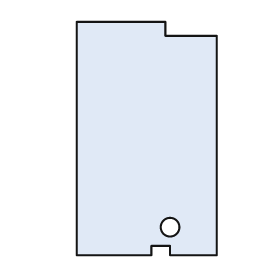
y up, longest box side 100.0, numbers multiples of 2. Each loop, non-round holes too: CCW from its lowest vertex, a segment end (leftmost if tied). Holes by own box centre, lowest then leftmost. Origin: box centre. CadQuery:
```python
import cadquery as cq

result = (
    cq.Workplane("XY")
    .moveTo(-30.0, -50.0)
    .lineTo(2.0, -50.0)
    .lineTo(2.0, -46.0)
    .lineTo(10.0, -46.0)
    .lineTo(10.0, -50.0)
    .lineTo(30.0, -50.0)
    .lineTo(30.0, 44.0)
    .lineTo(8.0, 44.0)
    .lineTo(8.0, 50.0)
    .lineTo(-30.0, 50.0)
    .close()
    .moveTo(10.0, -38.0)
    .circle(4.0)
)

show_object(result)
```